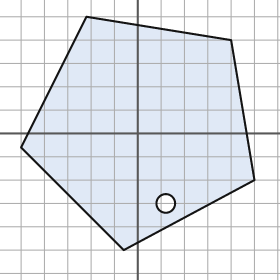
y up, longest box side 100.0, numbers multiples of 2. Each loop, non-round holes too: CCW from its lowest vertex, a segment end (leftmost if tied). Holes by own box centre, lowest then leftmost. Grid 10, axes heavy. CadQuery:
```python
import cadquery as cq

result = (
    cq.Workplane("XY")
    .moveTo(-6.0, -50.0)
    .lineTo(50.0, -20.0)
    .lineTo(40.0, 40.0)
    .lineTo(-22.0, 50.0)
    .lineTo(-50.0, -6.0)
    .close()
    .moveTo(12.0, -30.0)
    .circle(4.0)
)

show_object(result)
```